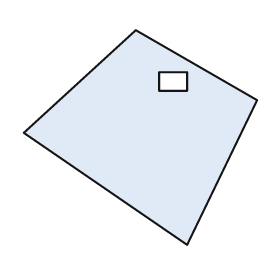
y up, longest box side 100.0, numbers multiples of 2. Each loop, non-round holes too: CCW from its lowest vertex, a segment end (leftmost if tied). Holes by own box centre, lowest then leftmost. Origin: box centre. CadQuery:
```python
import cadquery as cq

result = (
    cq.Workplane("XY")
    .moveTo(20.0, -46.0)
    .lineTo(50.0, 16.0)
    .lineTo(-2.0, 46.0)
    .lineTo(-50.0, 2.0)
    .close()
    .moveTo(8.0, 20.0)
    .lineTo(20.0, 20.0)
    .lineTo(20.0, 28.0)
    .lineTo(8.0, 28.0)
    .close()
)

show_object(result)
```